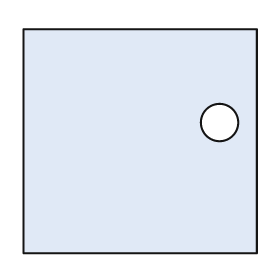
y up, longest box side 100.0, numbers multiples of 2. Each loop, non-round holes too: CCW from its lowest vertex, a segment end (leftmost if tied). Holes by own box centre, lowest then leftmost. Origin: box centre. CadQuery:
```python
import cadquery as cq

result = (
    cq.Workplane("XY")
    .moveTo(-50.0, -48.0)
    .lineTo(50.0, -48.0)
    .lineTo(50.0, 48.0)
    .lineTo(-50.0, 48.0)
    .close()
    .moveTo(34.0, 8.0)
    .circle(8.0)
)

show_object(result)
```